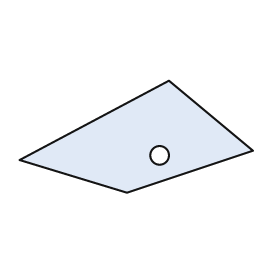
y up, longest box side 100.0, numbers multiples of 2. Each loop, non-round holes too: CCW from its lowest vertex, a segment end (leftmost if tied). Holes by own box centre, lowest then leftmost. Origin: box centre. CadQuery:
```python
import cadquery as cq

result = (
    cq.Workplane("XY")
    .moveTo(-4.0, -24.0)
    .lineTo(50.0, -6.0)
    .lineTo(14.0, 24.0)
    .lineTo(-50.0, -10.0)
    .close()
    .moveTo(10.0, -8.0)
    .circle(4.0)
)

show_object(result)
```